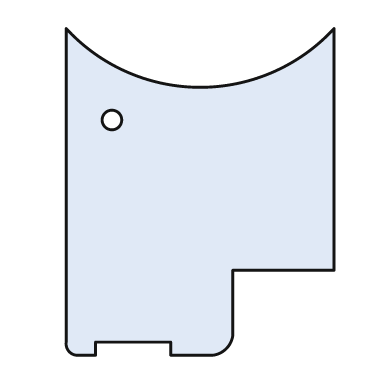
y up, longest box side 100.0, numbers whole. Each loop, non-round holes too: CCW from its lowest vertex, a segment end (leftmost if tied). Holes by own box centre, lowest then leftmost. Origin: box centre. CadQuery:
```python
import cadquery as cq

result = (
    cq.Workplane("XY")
    .moveTo(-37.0, -50.0)
    .lineTo(-32.0, -50.0)
    .lineTo(-32.0, -46.0)
    .lineTo(-9.0, -46.0)
    .lineTo(-9.0, -50.0)
    .lineTo(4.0, -50.0)
    .threePointArc((8.0, -48.0), (10.0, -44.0))
    .lineTo(10.0, -24.0)
    .lineTo(41.0, -24.0)
    .lineTo(41.0, 50.0)
    .threePointArc((0.0, 32.0), (-41.0, 50.0))
    .lineTo(-41.0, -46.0)
    .threePointArc((-40.0, -49.0), (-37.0, -50.0))
    .close()
    .moveTo(-27.0, 22.0)
    .circle(3.0)
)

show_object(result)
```